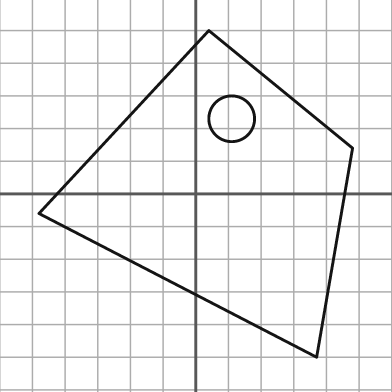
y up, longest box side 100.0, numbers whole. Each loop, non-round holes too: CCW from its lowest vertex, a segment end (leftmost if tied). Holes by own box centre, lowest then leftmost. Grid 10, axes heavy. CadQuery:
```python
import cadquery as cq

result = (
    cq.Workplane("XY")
    .moveTo(37.0, -50.0)
    .lineTo(48.0, 14.0)
    .lineTo(4.0, 50.0)
    .lineTo(-48.0, -6.0)
    .close()
    .moveTo(11.0, 23.0)
    .circle(7.0)
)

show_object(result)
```